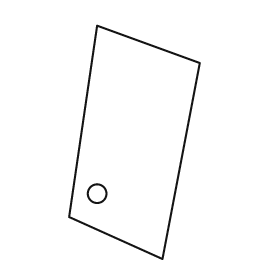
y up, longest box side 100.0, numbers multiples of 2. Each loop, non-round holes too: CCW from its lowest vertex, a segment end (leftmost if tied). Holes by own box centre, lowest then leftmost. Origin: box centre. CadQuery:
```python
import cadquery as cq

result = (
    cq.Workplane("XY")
    .moveTo(12.0, -50.0)
    .lineTo(28.0, 34.0)
    .lineTo(-16.0, 50.0)
    .lineTo(-28.0, -32.0)
    .close()
    .moveTo(-16.0, -22.0)
    .circle(4.0)
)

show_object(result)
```